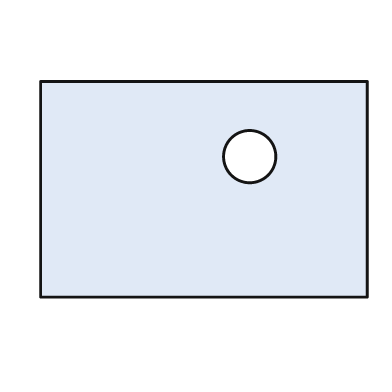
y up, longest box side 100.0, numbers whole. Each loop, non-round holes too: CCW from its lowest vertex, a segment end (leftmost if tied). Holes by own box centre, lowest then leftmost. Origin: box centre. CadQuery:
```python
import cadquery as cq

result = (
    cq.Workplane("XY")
    .moveTo(-50.0, -33.0)
    .lineTo(50.0, -33.0)
    .lineTo(50.0, 33.0)
    .lineTo(-50.0, 33.0)
    .close()
    .moveTo(14.0, 10.0)
    .circle(8.0)
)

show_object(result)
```